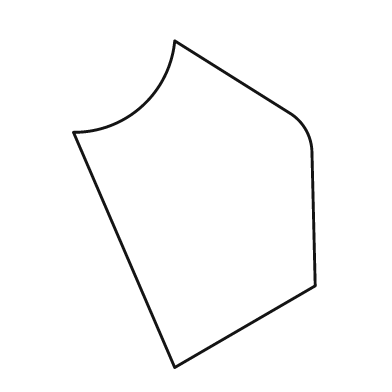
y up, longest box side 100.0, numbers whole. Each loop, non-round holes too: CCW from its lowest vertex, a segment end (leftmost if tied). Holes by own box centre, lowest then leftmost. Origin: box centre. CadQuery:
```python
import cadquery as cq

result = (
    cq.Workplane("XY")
    .moveTo(-6.0, -50.0)
    .lineTo(37.0, -25.0)
    .lineTo(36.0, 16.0)
    .threePointArc((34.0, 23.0), (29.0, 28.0))
    .lineTo(-6.0, 50.0)
    .threePointArc((-16.0, 30.0), (-37.0, 22.0))
    .close()
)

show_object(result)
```